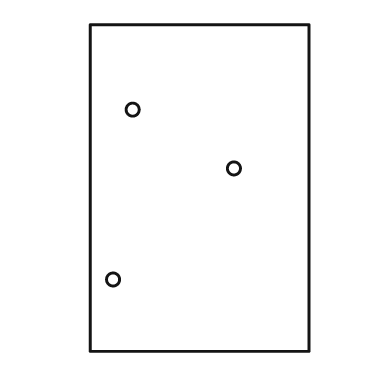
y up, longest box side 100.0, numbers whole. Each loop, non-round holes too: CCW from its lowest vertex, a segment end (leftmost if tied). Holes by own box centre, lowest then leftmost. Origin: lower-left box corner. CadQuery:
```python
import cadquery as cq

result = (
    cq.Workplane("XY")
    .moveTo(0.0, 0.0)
    .lineTo(67.0, 0.0)
    .lineTo(67.0, 100.0)
    .lineTo(0.0, 100.0)
    .close()
    .moveTo(7.0, 22.0)
    .circle(2.0)
    .moveTo(44.0, 56.0)
    .circle(2.0)
    .moveTo(13.0, 74.0)
    .circle(2.0)
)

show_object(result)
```